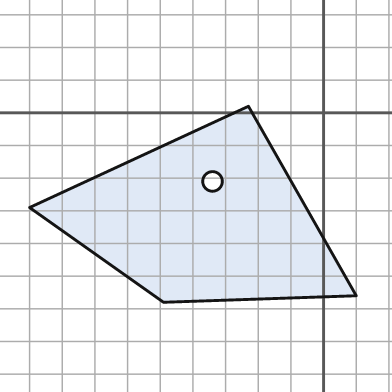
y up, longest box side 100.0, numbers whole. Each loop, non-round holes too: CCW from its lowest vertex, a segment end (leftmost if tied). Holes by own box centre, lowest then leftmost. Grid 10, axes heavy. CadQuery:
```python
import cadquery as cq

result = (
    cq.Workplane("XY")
    .moveTo(-49.0, -58.0)
    .lineTo(10.0, -56.0)
    .lineTo(-23.0, 2.0)
    .lineTo(-90.0, -29.0)
    .close()
    .moveTo(-34.0, -21.0)
    .circle(3.0)
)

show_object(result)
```